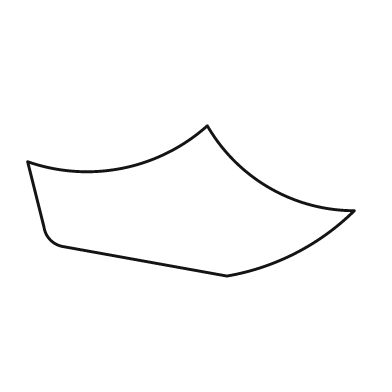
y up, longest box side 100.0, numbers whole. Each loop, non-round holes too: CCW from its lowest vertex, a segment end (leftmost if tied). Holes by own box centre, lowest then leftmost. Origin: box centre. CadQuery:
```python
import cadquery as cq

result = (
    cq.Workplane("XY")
    .moveTo(11.0, -23.0)
    .threePointArc((32.0, -16.0), (50.0, -3.0))
    .threePointArc((24.0, 4.0), (5.0, 23.0))
    .threePointArc((-21.0, 10.0), (-50.0, 12.0))
    .lineTo(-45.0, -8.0)
    .threePointArc((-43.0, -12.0), (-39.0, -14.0))
    .close()
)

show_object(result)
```